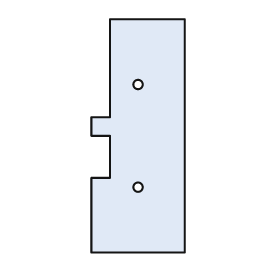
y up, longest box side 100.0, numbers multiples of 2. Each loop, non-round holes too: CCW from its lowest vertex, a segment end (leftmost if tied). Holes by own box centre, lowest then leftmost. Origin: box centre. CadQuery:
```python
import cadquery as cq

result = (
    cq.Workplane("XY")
    .moveTo(-20.0, -50.0)
    .lineTo(20.0, -50.0)
    .lineTo(20.0, 50.0)
    .lineTo(-12.0, 50.0)
    .lineTo(-12.0, 8.0)
    .lineTo(-20.0, 8.0)
    .lineTo(-20.0, 0.0)
    .lineTo(-12.0, 0.0)
    .lineTo(-12.0, -18.0)
    .lineTo(-20.0, -18.0)
    .close()
    .moveTo(0.0, -22.0)
    .circle(2.0)
    .moveTo(0.0, 22.0)
    .circle(2.0)
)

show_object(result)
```